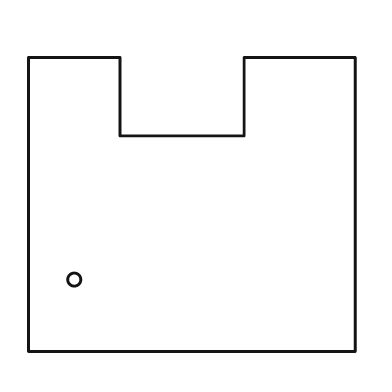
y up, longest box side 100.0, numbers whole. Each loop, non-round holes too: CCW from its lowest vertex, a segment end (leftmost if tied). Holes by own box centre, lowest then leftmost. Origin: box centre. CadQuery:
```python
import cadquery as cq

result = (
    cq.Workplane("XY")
    .moveTo(-50.0, -45.0)
    .lineTo(50.0, -45.0)
    .lineTo(50.0, 45.0)
    .lineTo(16.0, 45.0)
    .lineTo(16.0, 21.0)
    .lineTo(-22.0, 21.0)
    .lineTo(-22.0, 45.0)
    .lineTo(-50.0, 45.0)
    .close()
    .moveTo(-36.0, -23.0)
    .circle(2.0)
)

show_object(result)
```